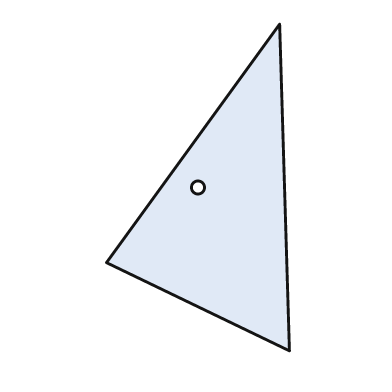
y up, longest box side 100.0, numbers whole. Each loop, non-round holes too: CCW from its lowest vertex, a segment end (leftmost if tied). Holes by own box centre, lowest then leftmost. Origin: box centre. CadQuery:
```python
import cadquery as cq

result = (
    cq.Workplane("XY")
    .moveTo(28.0, -50.0)
    .lineTo(25.0, 50.0)
    .lineTo(-28.0, -23.0)
    .close()
    .moveTo(0.0, 0.0)
    .circle(2.0)
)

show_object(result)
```